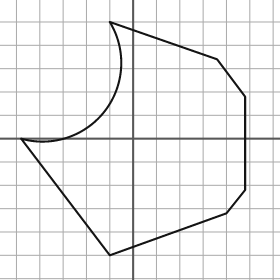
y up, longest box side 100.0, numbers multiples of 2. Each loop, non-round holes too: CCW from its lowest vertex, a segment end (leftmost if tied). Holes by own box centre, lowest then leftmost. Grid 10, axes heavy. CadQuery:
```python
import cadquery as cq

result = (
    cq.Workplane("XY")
    .moveTo(-10.0, -50.0)
    .lineTo(40.0, -32.0)
    .lineTo(48.0, -22.0)
    .lineTo(48.0, 18.0)
    .lineTo(36.0, 34.0)
    .lineTo(-10.0, 50.0)
    .threePointArc((-12.0, 12.0), (-48.0, 0.0))
    .close()
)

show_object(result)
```